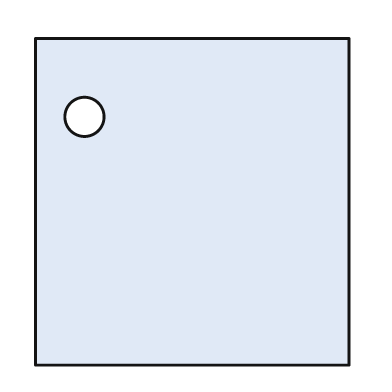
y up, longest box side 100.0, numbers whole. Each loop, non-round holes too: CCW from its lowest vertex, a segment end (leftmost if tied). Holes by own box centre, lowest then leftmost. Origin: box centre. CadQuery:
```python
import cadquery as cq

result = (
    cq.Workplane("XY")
    .moveTo(-48.0, -50.0)
    .lineTo(48.0, -50.0)
    .lineTo(48.0, 50.0)
    .lineTo(-48.0, 50.0)
    .close()
    .moveTo(-33.0, 26.0)
    .circle(6.0)
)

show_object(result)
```